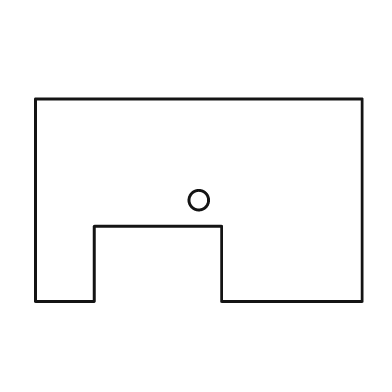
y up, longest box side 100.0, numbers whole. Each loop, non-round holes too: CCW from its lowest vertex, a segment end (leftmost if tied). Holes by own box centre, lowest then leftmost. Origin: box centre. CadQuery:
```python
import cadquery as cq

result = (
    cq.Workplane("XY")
    .moveTo(-50.0, -31.0)
    .lineTo(-32.0, -31.0)
    .lineTo(-32.0, -8.0)
    .lineTo(7.0, -8.0)
    .lineTo(7.0, -31.0)
    .lineTo(50.0, -31.0)
    .lineTo(50.0, 31.0)
    .lineTo(-50.0, 31.0)
    .close()
    .moveTo(0.0, 0.0)
    .circle(3.0)
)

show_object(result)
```